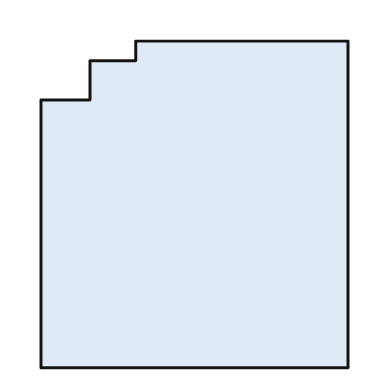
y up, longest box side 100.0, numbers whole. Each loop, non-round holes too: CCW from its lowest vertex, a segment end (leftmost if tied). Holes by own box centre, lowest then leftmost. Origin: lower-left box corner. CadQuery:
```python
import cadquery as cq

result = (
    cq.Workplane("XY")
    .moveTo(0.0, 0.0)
    .lineTo(94.0, 0.0)
    .lineTo(94.0, 100.0)
    .lineTo(29.0, 100.0)
    .lineTo(29.0, 94.0)
    .lineTo(15.0, 94.0)
    .lineTo(15.0, 82.0)
    .lineTo(0.0, 82.0)
    .close()
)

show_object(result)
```